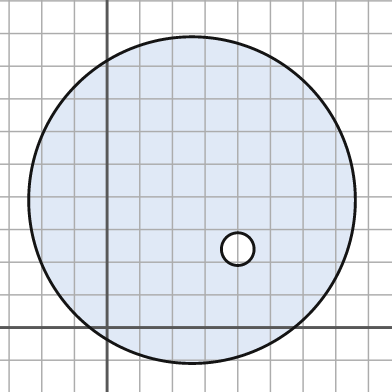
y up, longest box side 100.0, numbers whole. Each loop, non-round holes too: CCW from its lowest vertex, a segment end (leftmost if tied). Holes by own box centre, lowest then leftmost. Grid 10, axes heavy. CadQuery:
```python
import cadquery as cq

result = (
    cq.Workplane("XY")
    .moveTo(26.0, 39.0)
    .circle(50.0)
    .moveTo(40.0, 24.0)
    .circle(5.0)
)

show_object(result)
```